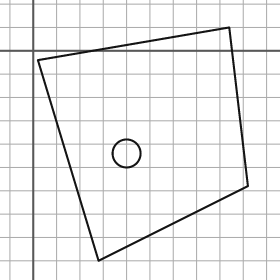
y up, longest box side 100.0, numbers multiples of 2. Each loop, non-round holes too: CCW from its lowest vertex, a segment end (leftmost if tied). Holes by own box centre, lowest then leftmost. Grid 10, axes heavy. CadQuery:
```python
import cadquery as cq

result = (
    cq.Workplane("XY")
    .moveTo(28.0, -90.0)
    .lineTo(92.0, -58.0)
    .lineTo(84.0, 10.0)
    .lineTo(2.0, -4.0)
    .close()
    .moveTo(40.0, -44.0)
    .circle(6.0)
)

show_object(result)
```